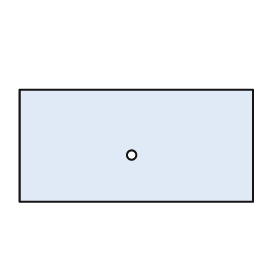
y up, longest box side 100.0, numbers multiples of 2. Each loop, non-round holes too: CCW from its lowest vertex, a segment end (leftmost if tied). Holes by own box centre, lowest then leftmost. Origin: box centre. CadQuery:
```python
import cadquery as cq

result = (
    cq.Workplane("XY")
    .moveTo(-50.0, -24.0)
    .lineTo(50.0, -24.0)
    .lineTo(50.0, 24.0)
    .lineTo(-50.0, 24.0)
    .close()
    .moveTo(-2.0, -4.0)
    .circle(2.0)
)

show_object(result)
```